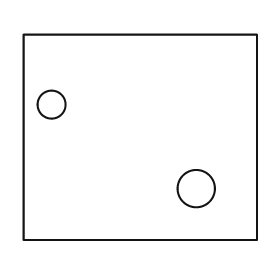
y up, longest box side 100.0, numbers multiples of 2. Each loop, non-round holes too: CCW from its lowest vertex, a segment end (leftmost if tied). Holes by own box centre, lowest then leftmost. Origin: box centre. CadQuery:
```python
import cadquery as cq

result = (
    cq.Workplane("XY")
    .moveTo(-50.0, -44.0)
    .lineTo(50.0, -44.0)
    .lineTo(50.0, 44.0)
    .lineTo(-50.0, 44.0)
    .close()
    .moveTo(24.0, -22.0)
    .circle(8.0)
    .moveTo(-38.0, 14.0)
    .circle(6.0)
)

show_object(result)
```